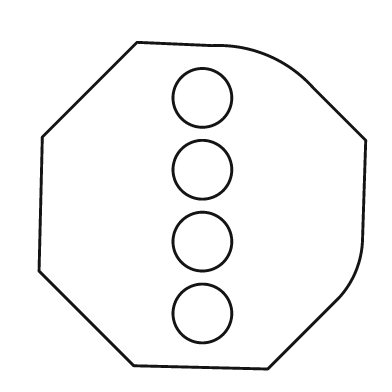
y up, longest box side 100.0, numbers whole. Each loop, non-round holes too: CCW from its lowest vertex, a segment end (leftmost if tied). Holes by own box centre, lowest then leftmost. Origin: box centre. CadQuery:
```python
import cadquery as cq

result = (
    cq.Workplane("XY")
    .moveTo(20.0, -50.0)
    .lineTo(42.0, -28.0)
    .threePointArc((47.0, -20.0), (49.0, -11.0))
    .lineTo(50.0, 20.0)
    .lineTo(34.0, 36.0)
    .threePointArc((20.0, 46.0), (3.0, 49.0))
    .lineTo(-20.0, 50.0)
    .lineTo(-49.0, 21.0)
    .lineTo(-50.0, -20.0)
    .lineTo(-21.0, -49.0)
    .close()
    .moveTo(0.0, -33.0)
    .circle(9.0)
    .moveTo(0.0, -11.0)
    .circle(9.0)
    .moveTo(0.0, 11.0)
    .circle(9.0)
    .moveTo(0.0, 33.0)
    .circle(9.0)
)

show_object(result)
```